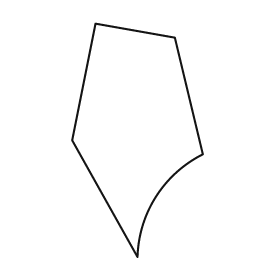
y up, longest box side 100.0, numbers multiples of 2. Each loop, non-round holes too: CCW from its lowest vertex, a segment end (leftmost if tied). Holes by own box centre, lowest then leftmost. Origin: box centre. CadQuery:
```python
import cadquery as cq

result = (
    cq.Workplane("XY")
    .moveTo(0.0, -50.0)
    .threePointArc((8.0, -24.0), (28.0, -6.0))
    .lineTo(16.0, 44.0)
    .lineTo(-18.0, 50.0)
    .lineTo(-28.0, 0.0)
    .close()
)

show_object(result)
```